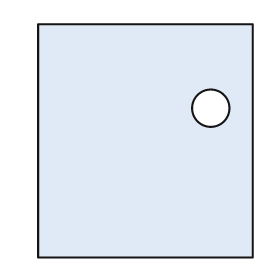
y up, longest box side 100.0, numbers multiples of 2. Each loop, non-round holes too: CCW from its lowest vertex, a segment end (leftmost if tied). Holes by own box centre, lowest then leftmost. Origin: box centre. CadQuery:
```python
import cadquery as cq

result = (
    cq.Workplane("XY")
    .moveTo(-46.0, -50.0)
    .lineTo(46.0, -50.0)
    .lineTo(46.0, 50.0)
    .lineTo(-46.0, 50.0)
    .close()
    .moveTo(28.0, 14.0)
    .circle(8.0)
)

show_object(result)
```